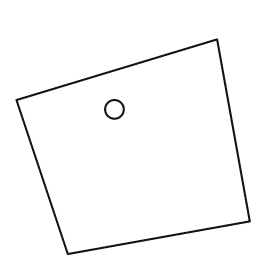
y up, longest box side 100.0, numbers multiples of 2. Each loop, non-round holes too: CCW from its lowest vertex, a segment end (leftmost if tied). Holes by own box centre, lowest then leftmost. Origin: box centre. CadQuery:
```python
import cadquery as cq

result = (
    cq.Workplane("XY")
    .moveTo(-28.0, -46.0)
    .lineTo(50.0, -32.0)
    .lineTo(36.0, 46.0)
    .lineTo(-50.0, 20.0)
    .close()
    .moveTo(-8.0, 16.0)
    .circle(4.0)
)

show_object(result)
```